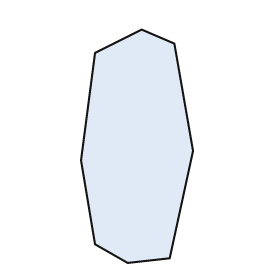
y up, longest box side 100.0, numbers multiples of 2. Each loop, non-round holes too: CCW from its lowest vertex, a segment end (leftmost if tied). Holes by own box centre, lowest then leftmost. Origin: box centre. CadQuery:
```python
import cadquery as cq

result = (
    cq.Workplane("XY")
    .moveTo(-4.0, -50.0)
    .lineTo(14.0, -48.0)
    .lineTo(24.0, -2.0)
    .lineTo(16.0, 44.0)
    .lineTo(2.0, 50.0)
    .lineTo(-18.0, 40.0)
    .lineTo(-24.0, -6.0)
    .lineTo(-18.0, -42.0)
    .close()
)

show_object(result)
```